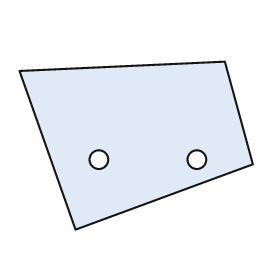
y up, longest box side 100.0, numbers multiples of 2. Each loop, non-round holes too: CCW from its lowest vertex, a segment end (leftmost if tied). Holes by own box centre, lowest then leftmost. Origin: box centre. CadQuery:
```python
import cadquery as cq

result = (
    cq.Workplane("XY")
    .moveTo(-26.0, -36.0)
    .lineTo(50.0, -8.0)
    .lineTo(38.0, 36.0)
    .lineTo(-50.0, 32.0)
    .close()
    .moveTo(-16.0, -6.0)
    .circle(4.0)
    .moveTo(26.0, -6.0)
    .circle(4.0)
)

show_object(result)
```